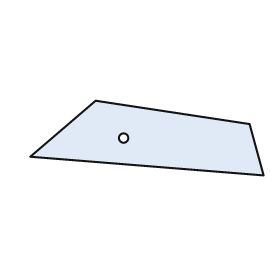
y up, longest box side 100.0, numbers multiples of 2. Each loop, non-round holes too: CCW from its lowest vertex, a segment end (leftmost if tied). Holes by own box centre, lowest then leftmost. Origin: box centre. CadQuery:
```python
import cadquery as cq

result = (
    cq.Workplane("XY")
    .moveTo(50.0, -16.0)
    .lineTo(44.0, 6.0)
    .lineTo(-22.0, 16.0)
    .lineTo(-50.0, -8.0)
    .close()
    .moveTo(-10.0, 0.0)
    .circle(2.0)
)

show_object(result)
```